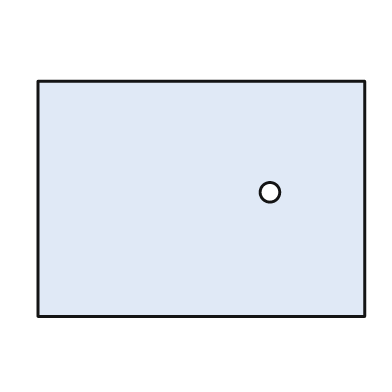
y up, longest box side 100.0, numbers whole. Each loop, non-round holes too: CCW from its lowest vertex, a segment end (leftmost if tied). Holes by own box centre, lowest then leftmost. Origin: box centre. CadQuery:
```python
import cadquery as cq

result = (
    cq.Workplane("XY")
    .moveTo(-50.0, -36.0)
    .lineTo(50.0, -36.0)
    .lineTo(50.0, 36.0)
    .lineTo(-50.0, 36.0)
    .close()
    .moveTo(21.0, 2.0)
    .circle(3.0)
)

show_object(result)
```